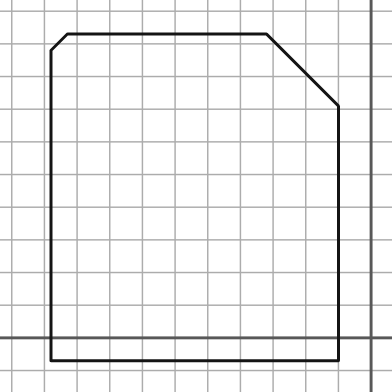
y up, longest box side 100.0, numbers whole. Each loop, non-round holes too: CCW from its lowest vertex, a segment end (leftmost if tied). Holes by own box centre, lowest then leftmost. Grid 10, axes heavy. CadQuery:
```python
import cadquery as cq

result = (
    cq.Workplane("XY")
    .moveTo(-98.0, -7.0)
    .lineTo(-10.0, -7.0)
    .lineTo(-10.0, 71.0)
    .lineTo(-32.0, 93.0)
    .lineTo(-93.0, 93.0)
    .lineTo(-98.0, 88.0)
    .close()
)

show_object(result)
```